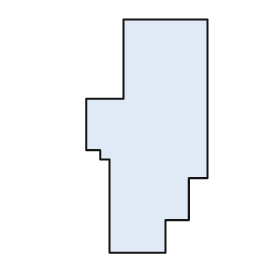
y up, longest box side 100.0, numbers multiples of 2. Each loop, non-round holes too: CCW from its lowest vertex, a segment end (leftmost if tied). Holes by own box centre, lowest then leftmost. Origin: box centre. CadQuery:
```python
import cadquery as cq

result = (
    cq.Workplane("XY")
    .moveTo(-16.0, -50.0)
    .lineTo(8.0, -50.0)
    .lineTo(8.0, -36.0)
    .lineTo(18.0, -36.0)
    .lineTo(18.0, -18.0)
    .lineTo(26.0, -18.0)
    .lineTo(26.0, 50.0)
    .lineTo(-10.0, 50.0)
    .lineTo(-10.0, 16.0)
    .lineTo(-26.0, 16.0)
    .lineTo(-26.0, -6.0)
    .lineTo(-20.0, -6.0)
    .lineTo(-20.0, -10.0)
    .lineTo(-16.0, -10.0)
    .close()
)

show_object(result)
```